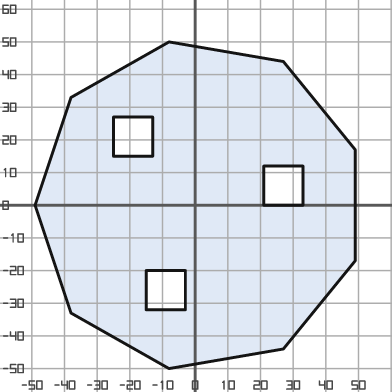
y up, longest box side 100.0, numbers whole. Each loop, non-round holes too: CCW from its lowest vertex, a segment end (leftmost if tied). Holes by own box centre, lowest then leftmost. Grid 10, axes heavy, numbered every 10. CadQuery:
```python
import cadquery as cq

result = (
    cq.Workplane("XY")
    .moveTo(-8.0, -50.0)
    .lineTo(27.0, -44.0)
    .lineTo(49.0, -17.0)
    .lineTo(49.0, 17.0)
    .lineTo(27.0, 44.0)
    .lineTo(-8.0, 50.0)
    .lineTo(-38.0, 33.0)
    .lineTo(-49.0, 0.0)
    .lineTo(-38.0, -33.0)
    .close()
    .moveTo(-15.0, -32.0)
    .lineTo(-3.0, -32.0)
    .lineTo(-3.0, -20.0)
    .lineTo(-15.0, -20.0)
    .close()
    .moveTo(21.0, 0.0)
    .lineTo(33.0, 0.0)
    .lineTo(33.0, 12.0)
    .lineTo(21.0, 12.0)
    .close()
    .moveTo(-25.0, 15.0)
    .lineTo(-13.0, 15.0)
    .lineTo(-13.0, 27.0)
    .lineTo(-25.0, 27.0)
    .close()
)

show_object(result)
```